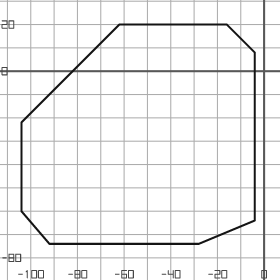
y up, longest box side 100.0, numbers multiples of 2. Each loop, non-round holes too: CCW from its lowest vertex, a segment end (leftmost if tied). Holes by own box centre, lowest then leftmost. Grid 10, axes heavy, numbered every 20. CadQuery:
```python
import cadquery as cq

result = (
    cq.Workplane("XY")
    .moveTo(-92.0, -74.0)
    .lineTo(-28.0, -74.0)
    .lineTo(-4.0, -64.0)
    .lineTo(-4.0, 8.0)
    .lineTo(-16.0, 20.0)
    .lineTo(-62.0, 20.0)
    .lineTo(-104.0, -22.0)
    .lineTo(-104.0, -60.0)
    .close()
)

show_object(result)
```